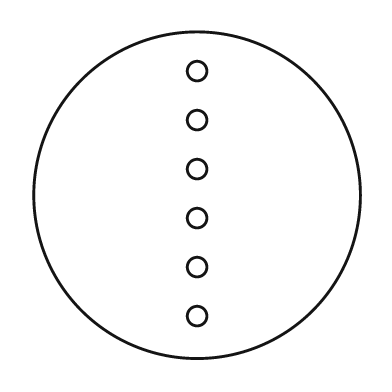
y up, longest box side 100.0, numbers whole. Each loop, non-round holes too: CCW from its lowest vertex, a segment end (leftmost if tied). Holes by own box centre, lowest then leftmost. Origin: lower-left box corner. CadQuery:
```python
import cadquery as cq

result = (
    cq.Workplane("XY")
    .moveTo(50.0, 50.0)
    .circle(50.0)
    .moveTo(50.0, 13.0)
    .circle(3.0)
    .moveTo(50.0, 28.0)
    .circle(3.0)
    .moveTo(50.0, 43.0)
    .circle(3.0)
    .moveTo(50.0, 58.0)
    .circle(3.0)
    .moveTo(50.0, 73.0)
    .circle(3.0)
    .moveTo(50.0, 88.0)
    .circle(3.0)
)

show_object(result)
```